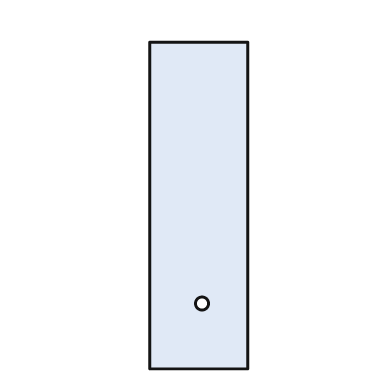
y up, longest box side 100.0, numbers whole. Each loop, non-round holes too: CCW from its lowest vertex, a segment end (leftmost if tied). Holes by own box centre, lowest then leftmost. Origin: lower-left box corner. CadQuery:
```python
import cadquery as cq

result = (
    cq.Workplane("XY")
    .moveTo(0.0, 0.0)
    .lineTo(30.0, 0.0)
    .lineTo(30.0, 100.0)
    .lineTo(0.0, 100.0)
    .close()
    .moveTo(16.0, 20.0)
    .circle(2.0)
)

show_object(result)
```